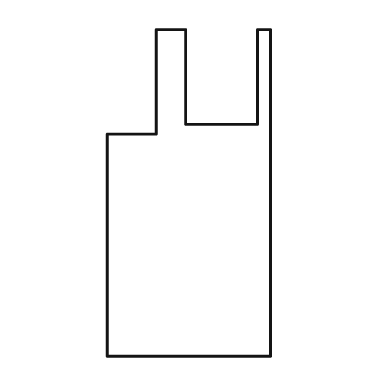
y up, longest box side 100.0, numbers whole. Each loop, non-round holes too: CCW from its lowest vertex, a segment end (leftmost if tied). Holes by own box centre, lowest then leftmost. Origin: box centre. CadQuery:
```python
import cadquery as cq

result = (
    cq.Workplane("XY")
    .moveTo(-25.0, -50.0)
    .lineTo(25.0, -50.0)
    .lineTo(25.0, 50.0)
    .lineTo(21.0, 50.0)
    .lineTo(21.0, 21.0)
    .lineTo(-1.0, 21.0)
    .lineTo(-1.0, 50.0)
    .lineTo(-10.0, 50.0)
    .lineTo(-10.0, 18.0)
    .lineTo(-25.0, 18.0)
    .close()
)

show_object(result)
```